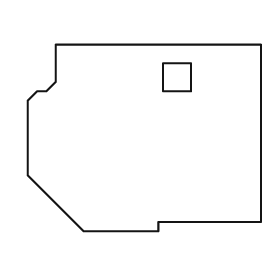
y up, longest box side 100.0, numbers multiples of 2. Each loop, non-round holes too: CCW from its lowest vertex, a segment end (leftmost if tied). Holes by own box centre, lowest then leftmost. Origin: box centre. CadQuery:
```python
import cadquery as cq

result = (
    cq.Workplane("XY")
    .moveTo(-26.0, -40.0)
    .lineTo(6.0, -40.0)
    .lineTo(6.0, -36.0)
    .lineTo(50.0, -36.0)
    .lineTo(50.0, 40.0)
    .lineTo(-38.0, 40.0)
    .lineTo(-38.0, 24.0)
    .lineTo(-42.0, 20.0)
    .lineTo(-46.0, 20.0)
    .lineTo(-50.0, 16.0)
    .lineTo(-50.0, -16.0)
    .close()
    .moveTo(8.0, 20.0)
    .lineTo(20.0, 20.0)
    .lineTo(20.0, 32.0)
    .lineTo(8.0, 32.0)
    .close()
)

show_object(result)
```